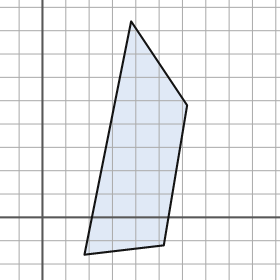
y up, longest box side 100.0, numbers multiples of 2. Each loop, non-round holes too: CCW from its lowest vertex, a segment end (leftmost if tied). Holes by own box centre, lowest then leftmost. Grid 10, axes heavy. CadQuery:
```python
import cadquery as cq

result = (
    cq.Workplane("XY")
    .moveTo(18.0, -16.0)
    .lineTo(52.0, -12.0)
    .lineTo(62.0, 48.0)
    .lineTo(38.0, 84.0)
    .close()
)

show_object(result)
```